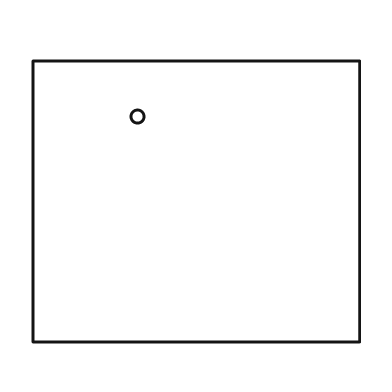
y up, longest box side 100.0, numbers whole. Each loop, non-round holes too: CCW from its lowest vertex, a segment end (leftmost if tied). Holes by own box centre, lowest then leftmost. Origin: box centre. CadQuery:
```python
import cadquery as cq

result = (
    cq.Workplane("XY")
    .moveTo(-50.0, -43.0)
    .lineTo(50.0, -43.0)
    .lineTo(50.0, 43.0)
    .lineTo(-50.0, 43.0)
    .close()
    .moveTo(-18.0, 26.0)
    .circle(2.0)
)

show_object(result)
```